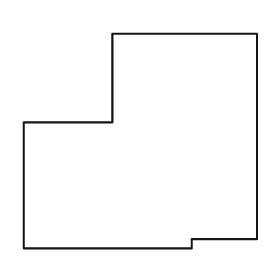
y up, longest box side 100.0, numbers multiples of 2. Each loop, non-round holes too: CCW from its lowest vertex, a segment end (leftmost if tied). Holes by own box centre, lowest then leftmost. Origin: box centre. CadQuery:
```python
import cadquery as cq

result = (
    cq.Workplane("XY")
    .moveTo(-50.0, -46.0)
    .lineTo(22.0, -46.0)
    .lineTo(22.0, -42.0)
    .lineTo(50.0, -42.0)
    .lineTo(50.0, 46.0)
    .lineTo(-12.0, 46.0)
    .lineTo(-12.0, 8.0)
    .lineTo(-50.0, 8.0)
    .close()
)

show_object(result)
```